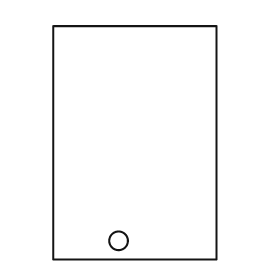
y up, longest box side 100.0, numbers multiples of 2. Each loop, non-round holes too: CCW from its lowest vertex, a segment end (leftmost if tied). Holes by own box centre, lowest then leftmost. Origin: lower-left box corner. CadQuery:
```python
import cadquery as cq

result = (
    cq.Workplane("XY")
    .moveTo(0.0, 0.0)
    .lineTo(70.0, 0.0)
    .lineTo(70.0, 100.0)
    .lineTo(0.0, 100.0)
    .close()
    .moveTo(28.0, 8.0)
    .circle(4.0)
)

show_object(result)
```